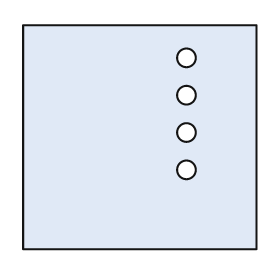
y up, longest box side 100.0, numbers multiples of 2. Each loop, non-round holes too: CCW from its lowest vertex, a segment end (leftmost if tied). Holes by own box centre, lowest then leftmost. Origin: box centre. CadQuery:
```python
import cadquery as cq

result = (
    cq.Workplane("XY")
    .moveTo(-50.0, -48.0)
    .lineTo(50.0, -48.0)
    .lineTo(50.0, 48.0)
    .lineTo(-50.0, 48.0)
    .close()
    .moveTo(20.0, -14.0)
    .circle(4.0)
    .moveTo(20.0, 2.0)
    .circle(4.0)
    .moveTo(20.0, 18.0)
    .circle(4.0)
    .moveTo(20.0, 34.0)
    .circle(4.0)
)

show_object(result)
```